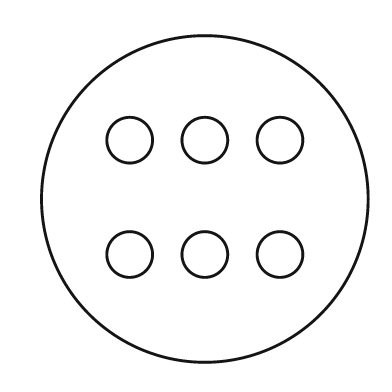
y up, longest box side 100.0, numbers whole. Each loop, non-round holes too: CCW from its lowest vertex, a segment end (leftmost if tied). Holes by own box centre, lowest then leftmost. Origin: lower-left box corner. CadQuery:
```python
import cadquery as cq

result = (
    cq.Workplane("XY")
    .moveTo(50.0, 50.0)
    .circle(50.0)
    .moveTo(27.0, 33.0)
    .circle(7.0)
    .moveTo(50.0, 33.0)
    .circle(7.0)
    .moveTo(73.0, 33.0)
    .circle(7.0)
    .moveTo(27.0, 68.0)
    .circle(7.0)
    .moveTo(50.0, 68.0)
    .circle(7.0)
    .moveTo(73.0, 68.0)
    .circle(7.0)
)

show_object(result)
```